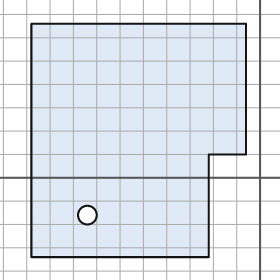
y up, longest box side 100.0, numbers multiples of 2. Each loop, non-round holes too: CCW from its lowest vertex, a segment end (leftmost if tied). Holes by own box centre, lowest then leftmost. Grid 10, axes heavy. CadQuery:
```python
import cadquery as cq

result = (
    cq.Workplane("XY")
    .moveTo(-98.0, -34.0)
    .lineTo(-22.0, -34.0)
    .lineTo(-22.0, 10.0)
    .lineTo(-6.0, 10.0)
    .lineTo(-6.0, 66.0)
    .lineTo(-98.0, 66.0)
    .close()
    .moveTo(-74.0, -16.0)
    .circle(4.0)
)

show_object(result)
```